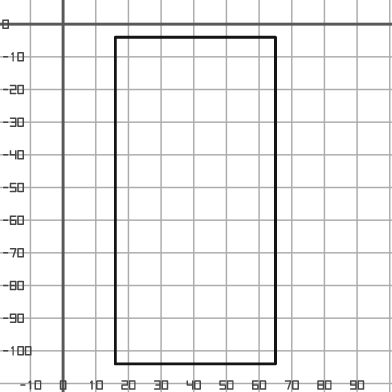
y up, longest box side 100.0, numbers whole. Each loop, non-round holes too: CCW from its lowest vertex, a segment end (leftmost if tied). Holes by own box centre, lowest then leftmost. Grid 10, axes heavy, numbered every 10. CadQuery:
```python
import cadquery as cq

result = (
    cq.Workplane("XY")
    .moveTo(16.0, -104.0)
    .lineTo(65.0, -104.0)
    .lineTo(65.0, -4.0)
    .lineTo(16.0, -4.0)
    .close()
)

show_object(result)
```